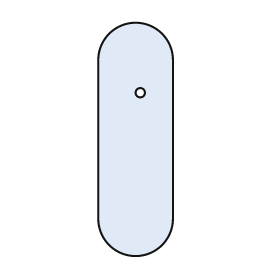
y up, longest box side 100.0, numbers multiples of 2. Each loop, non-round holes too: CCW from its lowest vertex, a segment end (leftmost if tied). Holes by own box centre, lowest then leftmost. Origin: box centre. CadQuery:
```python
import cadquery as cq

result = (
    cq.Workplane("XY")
    .moveTo(-16.0, -34.0)
    .threePointArc((0.0, -50.0), (16.0, -34.0))
    .lineTo(16.0, 34.0)
    .threePointArc((0.0, 50.0), (-16.0, 34.0))
    .close()
    .moveTo(2.0, 20.0)
    .circle(2.0)
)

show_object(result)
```